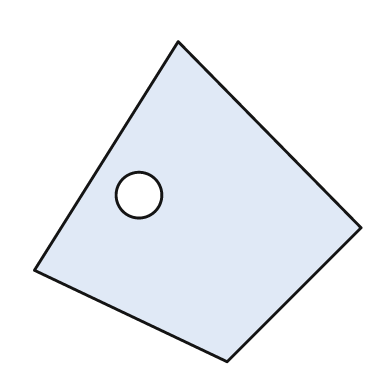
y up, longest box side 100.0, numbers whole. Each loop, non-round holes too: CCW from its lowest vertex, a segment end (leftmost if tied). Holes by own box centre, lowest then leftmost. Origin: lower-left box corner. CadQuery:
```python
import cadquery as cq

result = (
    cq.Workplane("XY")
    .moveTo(59.0, 0.0)
    .lineTo(100.0, 41.0)
    .lineTo(44.0, 98.0)
    .lineTo(0.0, 28.0)
    .close()
    .moveTo(32.0, 51.0)
    .circle(7.0)
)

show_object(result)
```